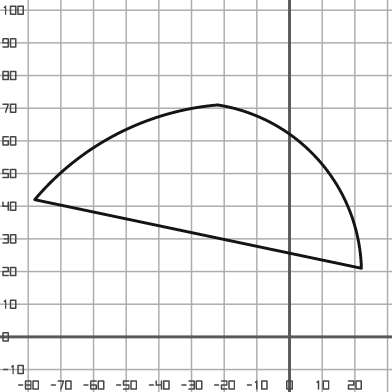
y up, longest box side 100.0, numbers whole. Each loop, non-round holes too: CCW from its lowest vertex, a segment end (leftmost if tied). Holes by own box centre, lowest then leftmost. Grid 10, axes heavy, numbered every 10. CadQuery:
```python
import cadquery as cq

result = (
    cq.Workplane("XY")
    .moveTo(22.0, 21.0)
    .threePointArc((9.0, 54.0), (-22.0, 71.0))
    .threePointArc((-53.0, 62.0), (-78.0, 42.0))
    .close()
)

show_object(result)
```